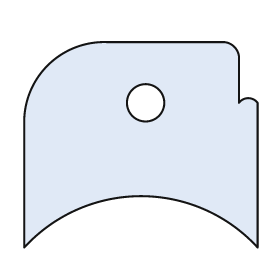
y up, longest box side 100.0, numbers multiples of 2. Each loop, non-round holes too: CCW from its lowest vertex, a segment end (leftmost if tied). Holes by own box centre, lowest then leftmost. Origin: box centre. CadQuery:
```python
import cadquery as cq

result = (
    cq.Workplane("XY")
    .moveTo(-50.0, -44.0)
    .threePointArc((0.0, -22.0), (50.0, -44.0))
    .lineTo(50.0, 18.0)
    .threePointArc((46.0, 20.0), (42.0, 18.0))
    .lineTo(42.0, 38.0)
    .threePointArc((40.0, 42.0), (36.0, 44.0))
    .lineTo(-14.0, 44.0)
    .threePointArc((-40.0, 34.0), (-50.0, 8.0))
    .close()
    .moveTo(2.0, 18.0)
    .circle(8.0)
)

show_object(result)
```